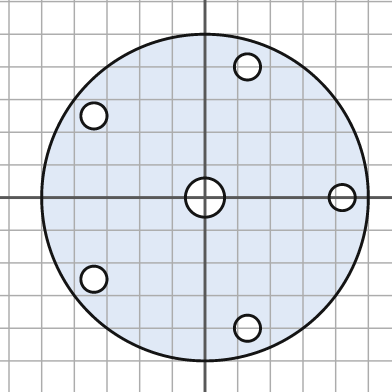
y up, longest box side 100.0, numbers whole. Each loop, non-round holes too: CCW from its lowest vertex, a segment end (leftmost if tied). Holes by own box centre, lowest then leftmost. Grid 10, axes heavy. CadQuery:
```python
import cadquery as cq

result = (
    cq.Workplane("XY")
    .moveTo(0.0, 0.0)
    .circle(50.0)
    .moveTo(13.0, -40.0)
    .circle(4.0)
    .moveTo(-34.0, -25.0)
    .circle(4.0)
    .moveTo(0.0, 0.0)
    .circle(6.0)
    .moveTo(42.0, 0.0)
    .circle(4.0)
    .moveTo(-34.0, 25.0)
    .circle(4.0)
    .moveTo(13.0, 40.0)
    .circle(4.0)
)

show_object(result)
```